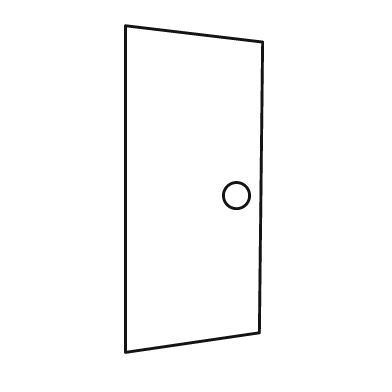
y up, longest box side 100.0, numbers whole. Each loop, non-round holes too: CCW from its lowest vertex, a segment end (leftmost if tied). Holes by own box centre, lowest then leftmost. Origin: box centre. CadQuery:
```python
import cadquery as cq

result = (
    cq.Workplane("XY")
    .moveTo(-21.0, -50.0)
    .lineTo(20.0, -44.0)
    .lineTo(21.0, 45.0)
    .lineTo(-21.0, 50.0)
    .close()
    .moveTo(13.0, -2.0)
    .circle(4.0)
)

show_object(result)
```